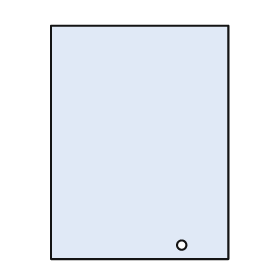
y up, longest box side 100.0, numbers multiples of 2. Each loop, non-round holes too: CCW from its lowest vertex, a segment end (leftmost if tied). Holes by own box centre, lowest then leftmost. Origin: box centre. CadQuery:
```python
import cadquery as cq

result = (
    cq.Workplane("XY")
    .moveTo(-38.0, -50.0)
    .lineTo(38.0, -50.0)
    .lineTo(38.0, 50.0)
    .lineTo(-38.0, 50.0)
    .close()
    .moveTo(18.0, -44.0)
    .circle(2.0)
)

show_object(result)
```